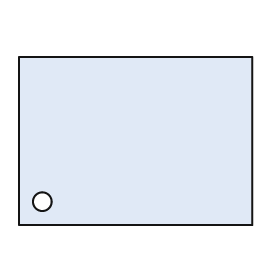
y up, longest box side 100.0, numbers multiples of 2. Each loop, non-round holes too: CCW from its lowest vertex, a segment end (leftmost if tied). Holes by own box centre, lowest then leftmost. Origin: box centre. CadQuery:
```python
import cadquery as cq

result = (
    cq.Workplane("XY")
    .moveTo(-50.0, -36.0)
    .lineTo(50.0, -36.0)
    .lineTo(50.0, 36.0)
    .lineTo(-50.0, 36.0)
    .close()
    .moveTo(-40.0, -26.0)
    .circle(4.0)
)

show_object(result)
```